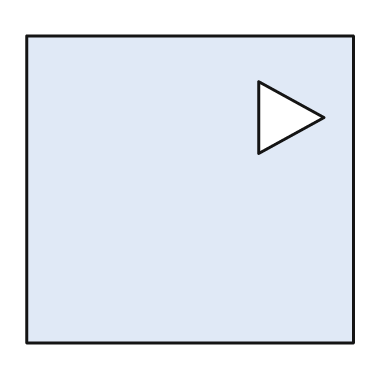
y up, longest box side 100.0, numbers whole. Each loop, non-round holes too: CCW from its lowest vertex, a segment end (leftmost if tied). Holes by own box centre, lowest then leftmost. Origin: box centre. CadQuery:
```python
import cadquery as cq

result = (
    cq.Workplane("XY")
    .moveTo(-50.0, -47.0)
    .lineTo(50.0, -47.0)
    .lineTo(50.0, 47.0)
    .lineTo(-50.0, 47.0)
    .close()
    .moveTo(21.0, 11.0)
    .lineTo(41.0, 22.0)
    .lineTo(21.0, 33.0)
    .close()
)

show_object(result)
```